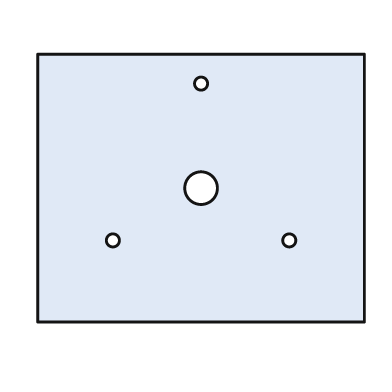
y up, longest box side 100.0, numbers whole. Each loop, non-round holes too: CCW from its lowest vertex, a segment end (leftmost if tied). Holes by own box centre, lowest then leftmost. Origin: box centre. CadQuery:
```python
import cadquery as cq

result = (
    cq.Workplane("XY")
    .moveTo(-50.0, -41.0)
    .lineTo(50.0, -41.0)
    .lineTo(50.0, 41.0)
    .lineTo(-50.0, 41.0)
    .close()
    .moveTo(-27.0, -16.0)
    .circle(2.0)
    .moveTo(27.0, -16.0)
    .circle(2.0)
    .moveTo(0.0, 0.0)
    .circle(5.0)
    .moveTo(0.0, 32.0)
    .circle(2.0)
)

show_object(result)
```